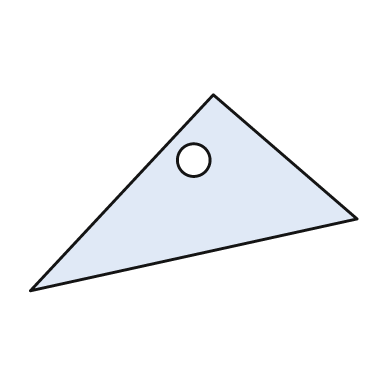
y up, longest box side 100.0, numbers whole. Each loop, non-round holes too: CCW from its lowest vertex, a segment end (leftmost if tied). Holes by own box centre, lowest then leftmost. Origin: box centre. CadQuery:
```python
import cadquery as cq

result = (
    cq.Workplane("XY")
    .moveTo(-50.0, -30.0)
    .lineTo(50.0, -8.0)
    .lineTo(6.0, 30.0)
    .close()
    .moveTo(0.0, 10.0)
    .circle(5.0)
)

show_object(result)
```